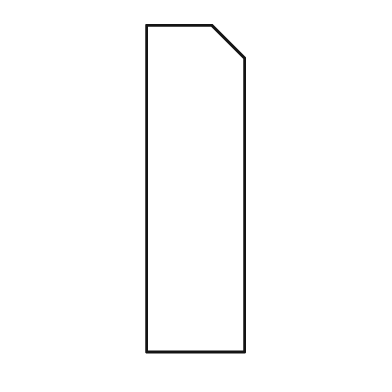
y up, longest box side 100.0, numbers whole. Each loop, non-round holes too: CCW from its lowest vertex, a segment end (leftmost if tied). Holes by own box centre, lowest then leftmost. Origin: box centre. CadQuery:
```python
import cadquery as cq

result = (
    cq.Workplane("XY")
    .moveTo(-15.0, -50.0)
    .lineTo(15.0, -50.0)
    .lineTo(15.0, 40.0)
    .lineTo(5.0, 50.0)
    .lineTo(-15.0, 50.0)
    .close()
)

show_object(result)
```